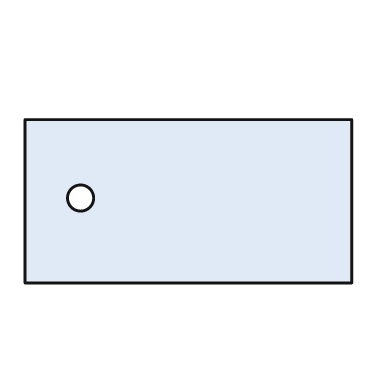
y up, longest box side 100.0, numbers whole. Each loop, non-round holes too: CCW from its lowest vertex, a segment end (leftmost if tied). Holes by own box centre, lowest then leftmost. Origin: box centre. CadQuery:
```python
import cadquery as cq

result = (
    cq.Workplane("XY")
    .moveTo(-50.0, -25.0)
    .lineTo(50.0, -25.0)
    .lineTo(50.0, 25.0)
    .lineTo(-50.0, 25.0)
    .close()
    .moveTo(-33.0, 1.0)
    .circle(4.0)
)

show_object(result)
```